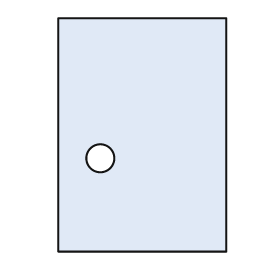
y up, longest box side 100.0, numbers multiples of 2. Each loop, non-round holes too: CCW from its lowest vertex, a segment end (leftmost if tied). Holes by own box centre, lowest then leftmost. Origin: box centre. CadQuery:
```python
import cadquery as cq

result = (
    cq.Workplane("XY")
    .moveTo(-36.0, -50.0)
    .lineTo(36.0, -50.0)
    .lineTo(36.0, 50.0)
    .lineTo(-36.0, 50.0)
    .close()
    .moveTo(-18.0, -10.0)
    .circle(6.0)
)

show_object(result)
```